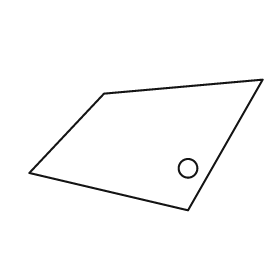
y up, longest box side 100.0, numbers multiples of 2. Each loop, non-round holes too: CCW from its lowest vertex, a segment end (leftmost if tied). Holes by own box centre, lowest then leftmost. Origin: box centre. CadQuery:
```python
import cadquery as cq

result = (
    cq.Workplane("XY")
    .moveTo(18.0, -28.0)
    .lineTo(50.0, 28.0)
    .lineTo(-18.0, 22.0)
    .lineTo(-50.0, -12.0)
    .close()
    .moveTo(18.0, -10.0)
    .circle(4.0)
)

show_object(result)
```